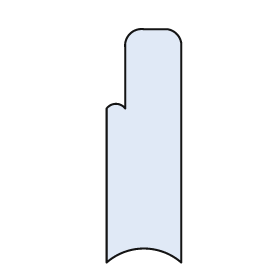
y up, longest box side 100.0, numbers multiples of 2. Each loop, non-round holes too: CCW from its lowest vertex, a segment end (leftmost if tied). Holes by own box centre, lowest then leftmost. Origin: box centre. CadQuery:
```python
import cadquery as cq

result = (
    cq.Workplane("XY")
    .moveTo(-16.0, -50.0)
    .threePointArc((0.0, -44.0), (16.0, -50.0))
    .lineTo(16.0, 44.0)
    .threePointArc((14.0, 48.0), (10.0, 50.0))
    .lineTo(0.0, 50.0)
    .threePointArc((-6.0, 48.0), (-8.0, 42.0))
    .lineTo(-8.0, 16.0)
    .threePointArc((-12.0, 18.0), (-16.0, 16.0))
    .close()
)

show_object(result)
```